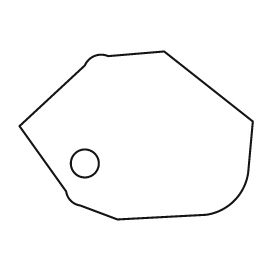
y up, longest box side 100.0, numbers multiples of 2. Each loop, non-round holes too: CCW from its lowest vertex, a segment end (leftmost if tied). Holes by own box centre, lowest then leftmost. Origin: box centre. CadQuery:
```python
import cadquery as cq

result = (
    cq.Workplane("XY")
    .moveTo(-8.0, -36.0)
    .lineTo(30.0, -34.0)
    .threePointArc((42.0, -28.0), (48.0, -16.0))
    .lineTo(50.0, 6.0)
    .lineTo(12.0, 36.0)
    .lineTo(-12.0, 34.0)
    .threePointArc((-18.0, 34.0), (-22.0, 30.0))
    .lineTo(-50.0, 4.0)
    .lineTo(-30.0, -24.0)
    .threePointArc((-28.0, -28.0), (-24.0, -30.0))
    .close()
    .moveTo(-22.0, -12.0)
    .circle(6.0)
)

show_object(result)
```